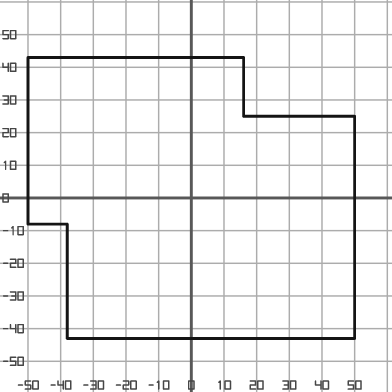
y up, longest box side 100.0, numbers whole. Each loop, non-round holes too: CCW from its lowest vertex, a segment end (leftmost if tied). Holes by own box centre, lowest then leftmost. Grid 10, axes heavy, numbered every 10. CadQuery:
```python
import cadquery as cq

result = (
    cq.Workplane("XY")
    .moveTo(-38.0, -43.0)
    .lineTo(50.0, -43.0)
    .lineTo(50.0, 25.0)
    .lineTo(16.0, 25.0)
    .lineTo(16.0, 43.0)
    .lineTo(-50.0, 43.0)
    .lineTo(-50.0, -8.0)
    .lineTo(-38.0, -8.0)
    .close()
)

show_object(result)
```